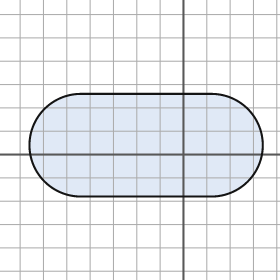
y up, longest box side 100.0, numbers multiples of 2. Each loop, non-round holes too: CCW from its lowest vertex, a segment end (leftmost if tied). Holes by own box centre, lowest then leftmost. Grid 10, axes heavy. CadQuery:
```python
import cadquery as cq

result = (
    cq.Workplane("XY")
    .moveTo(-44.0, -18.0)
    .lineTo(12.0, -18.0)
    .threePointArc((34.0, 4.0), (12.0, 26.0))
    .lineTo(-44.0, 26.0)
    .threePointArc((-66.0, 4.0), (-44.0, -18.0))
    .close()
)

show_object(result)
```